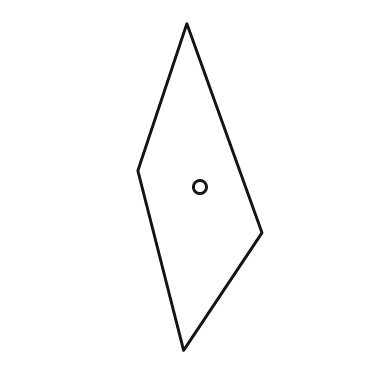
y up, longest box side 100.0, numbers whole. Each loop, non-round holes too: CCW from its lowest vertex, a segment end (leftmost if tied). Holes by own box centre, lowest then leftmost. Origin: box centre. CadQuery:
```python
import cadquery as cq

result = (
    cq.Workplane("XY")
    .moveTo(-5.0, -50.0)
    .lineTo(19.0, -14.0)
    .lineTo(-4.0, 50.0)
    .lineTo(-19.0, 5.0)
    .close()
    .moveTo(0.0, 0.0)
    .circle(2.0)
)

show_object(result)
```